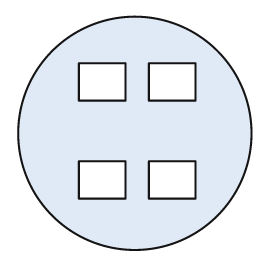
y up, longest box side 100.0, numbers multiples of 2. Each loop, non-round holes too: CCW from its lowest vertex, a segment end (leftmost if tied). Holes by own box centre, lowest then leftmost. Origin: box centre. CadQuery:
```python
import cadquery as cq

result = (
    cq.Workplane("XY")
    .moveTo(0.0, 0.0)
    .circle(50.0)
    .moveTo(-24.0, -28.0)
    .lineTo(-4.0, -28.0)
    .lineTo(-4.0, -12.0)
    .lineTo(-24.0, -12.0)
    .close()
    .moveTo(6.0, -28.0)
    .lineTo(26.0, -28.0)
    .lineTo(26.0, -12.0)
    .lineTo(6.0, -12.0)
    .close()
    .moveTo(-24.0, 14.0)
    .lineTo(-4.0, 14.0)
    .lineTo(-4.0, 30.0)
    .lineTo(-24.0, 30.0)
    .close()
    .moveTo(6.0, 14.0)
    .lineTo(26.0, 14.0)
    .lineTo(26.0, 30.0)
    .lineTo(6.0, 30.0)
    .close()
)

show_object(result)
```